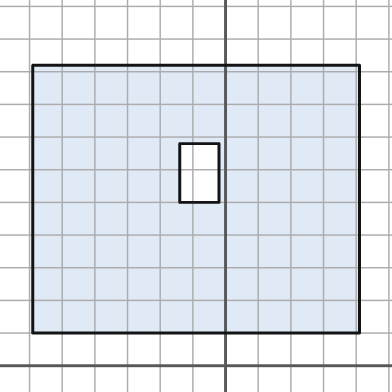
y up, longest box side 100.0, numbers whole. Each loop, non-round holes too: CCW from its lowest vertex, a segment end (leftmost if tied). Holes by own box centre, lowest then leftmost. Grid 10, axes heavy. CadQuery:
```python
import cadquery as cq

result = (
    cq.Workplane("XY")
    .moveTo(-59.0, 10.0)
    .lineTo(41.0, 10.0)
    .lineTo(41.0, 92.0)
    .lineTo(-59.0, 92.0)
    .close()
    .moveTo(-14.0, 50.0)
    .lineTo(-2.0, 50.0)
    .lineTo(-2.0, 68.0)
    .lineTo(-14.0, 68.0)
    .close()
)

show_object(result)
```